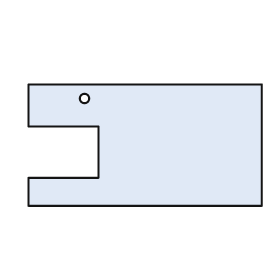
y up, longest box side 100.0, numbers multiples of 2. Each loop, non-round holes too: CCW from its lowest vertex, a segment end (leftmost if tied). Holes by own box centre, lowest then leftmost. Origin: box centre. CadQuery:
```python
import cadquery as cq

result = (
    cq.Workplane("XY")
    .moveTo(-50.0, -26.0)
    .lineTo(50.0, -26.0)
    .lineTo(50.0, 26.0)
    .lineTo(-50.0, 26.0)
    .lineTo(-50.0, 8.0)
    .lineTo(-20.0, 8.0)
    .lineTo(-20.0, -14.0)
    .lineTo(-50.0, -14.0)
    .close()
    .moveTo(-26.0, 20.0)
    .circle(2.0)
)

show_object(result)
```